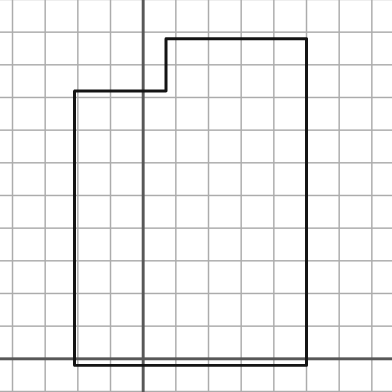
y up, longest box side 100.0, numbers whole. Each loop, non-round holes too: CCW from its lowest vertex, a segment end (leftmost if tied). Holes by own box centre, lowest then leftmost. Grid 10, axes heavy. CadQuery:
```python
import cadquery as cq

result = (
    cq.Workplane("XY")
    .moveTo(-21.0, -2.0)
    .lineTo(50.0, -2.0)
    .lineTo(50.0, 98.0)
    .lineTo(7.0, 98.0)
    .lineTo(7.0, 82.0)
    .lineTo(-21.0, 82.0)
    .close()
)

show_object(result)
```